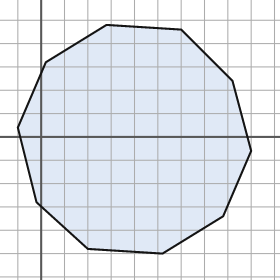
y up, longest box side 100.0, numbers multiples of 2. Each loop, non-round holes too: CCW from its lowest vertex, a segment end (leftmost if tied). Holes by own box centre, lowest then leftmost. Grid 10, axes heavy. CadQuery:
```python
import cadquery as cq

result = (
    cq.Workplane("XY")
    .moveTo(52.0, -50.0)
    .lineTo(78.0, -34.0)
    .lineTo(90.0, -6.0)
    .lineTo(82.0, 24.0)
    .lineTo(60.0, 46.0)
    .lineTo(28.0, 48.0)
    .lineTo(2.0, 32.0)
    .lineTo(-10.0, 4.0)
    .lineTo(-2.0, -28.0)
    .lineTo(20.0, -48.0)
    .close()
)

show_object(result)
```